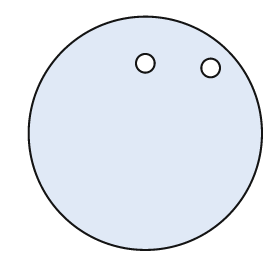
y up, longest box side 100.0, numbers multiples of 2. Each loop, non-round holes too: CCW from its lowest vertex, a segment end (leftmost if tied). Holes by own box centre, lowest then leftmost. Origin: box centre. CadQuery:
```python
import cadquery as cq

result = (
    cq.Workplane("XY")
    .moveTo(0.0, 0.0)
    .circle(50.0)
    .moveTo(28.0, 28.0)
    .circle(4.0)
    .moveTo(0.0, 30.0)
    .circle(4.0)
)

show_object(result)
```